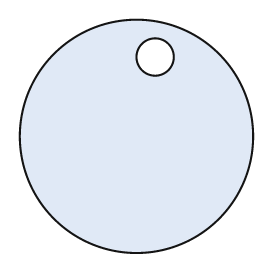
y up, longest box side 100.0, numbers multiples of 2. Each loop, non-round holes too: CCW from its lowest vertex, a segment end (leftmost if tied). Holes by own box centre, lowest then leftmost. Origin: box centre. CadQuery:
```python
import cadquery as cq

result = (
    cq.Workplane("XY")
    .moveTo(0.0, 0.0)
    .circle(50.0)
    .moveTo(8.0, 34.0)
    .circle(8.0)
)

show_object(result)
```